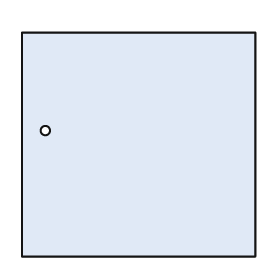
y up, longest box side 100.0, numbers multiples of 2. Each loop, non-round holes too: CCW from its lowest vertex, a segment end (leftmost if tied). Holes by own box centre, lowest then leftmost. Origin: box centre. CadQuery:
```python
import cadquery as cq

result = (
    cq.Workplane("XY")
    .moveTo(-50.0, -48.0)
    .lineTo(50.0, -48.0)
    .lineTo(50.0, 48.0)
    .lineTo(-50.0, 48.0)
    .close()
    .moveTo(-40.0, 6.0)
    .circle(2.0)
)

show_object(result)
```